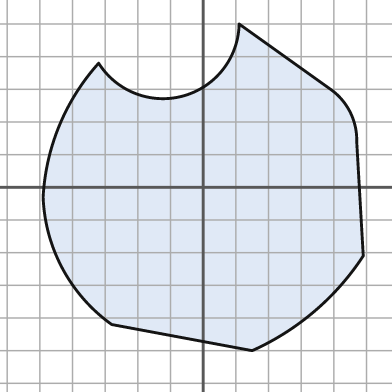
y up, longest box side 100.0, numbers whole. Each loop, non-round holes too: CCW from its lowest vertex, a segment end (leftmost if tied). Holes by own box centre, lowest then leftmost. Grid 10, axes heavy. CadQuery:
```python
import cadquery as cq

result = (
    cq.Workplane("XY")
    .moveTo(15.0, -50.0)
    .threePointArc((34.0, -38.0), (49.0, -21.0))
    .lineTo(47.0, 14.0)
    .threePointArc((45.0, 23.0), (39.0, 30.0))
    .lineTo(11.0, 50.0)
    .threePointArc((-6.0, 28.0), (-32.0, 38.0))
    .threePointArc((-44.0, 19.0), (-49.0, -3.0))
    .threePointArc((-43.0, -25.0), (-28.0, -42.0))
    .close()
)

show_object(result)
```